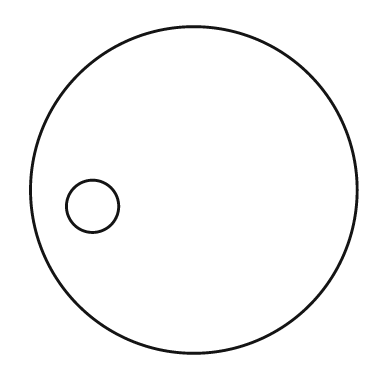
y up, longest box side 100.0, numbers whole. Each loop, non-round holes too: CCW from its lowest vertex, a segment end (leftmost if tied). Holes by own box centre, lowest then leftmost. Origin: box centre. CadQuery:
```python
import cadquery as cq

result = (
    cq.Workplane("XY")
    .moveTo(0.0, 0.0)
    .circle(50.0)
    .moveTo(-31.0, -5.0)
    .circle(8.0)
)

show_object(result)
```